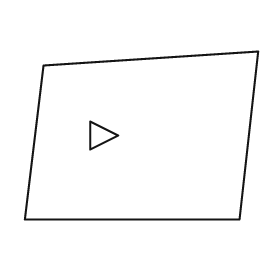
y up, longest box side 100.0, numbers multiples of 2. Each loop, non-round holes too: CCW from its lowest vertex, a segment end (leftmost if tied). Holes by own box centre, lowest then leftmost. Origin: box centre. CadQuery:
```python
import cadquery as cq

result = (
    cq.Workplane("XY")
    .moveTo(-50.0, -36.0)
    .lineTo(42.0, -36.0)
    .lineTo(50.0, 36.0)
    .lineTo(-42.0, 30.0)
    .close()
    .moveTo(-22.0, -6.0)
    .lineTo(-10.0, 0.0)
    .lineTo(-22.0, 6.0)
    .close()
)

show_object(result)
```